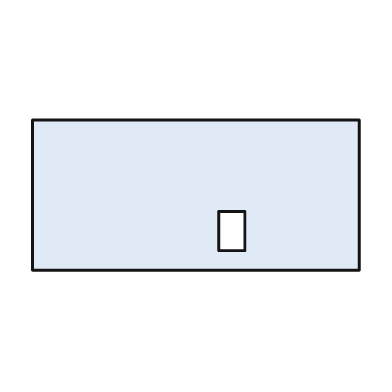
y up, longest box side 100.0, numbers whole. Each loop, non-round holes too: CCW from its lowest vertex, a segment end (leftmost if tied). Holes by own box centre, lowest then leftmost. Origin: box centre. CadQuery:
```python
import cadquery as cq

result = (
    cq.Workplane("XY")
    .moveTo(-50.0, -23.0)
    .lineTo(50.0, -23.0)
    .lineTo(50.0, 23.0)
    .lineTo(-50.0, 23.0)
    .close()
    .moveTo(7.0, -17.0)
    .lineTo(15.0, -17.0)
    .lineTo(15.0, -5.0)
    .lineTo(7.0, -5.0)
    .close()
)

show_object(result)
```